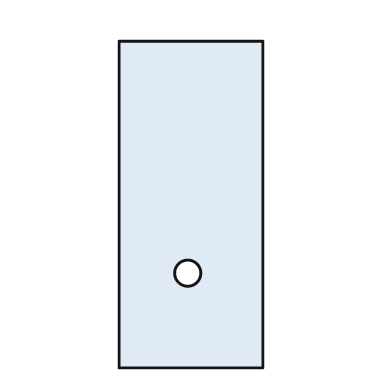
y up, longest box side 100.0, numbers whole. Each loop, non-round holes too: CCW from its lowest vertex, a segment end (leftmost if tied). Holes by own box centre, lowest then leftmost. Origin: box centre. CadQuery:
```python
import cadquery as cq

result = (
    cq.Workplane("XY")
    .moveTo(-22.0, -50.0)
    .lineTo(22.0, -50.0)
    .lineTo(22.0, 50.0)
    .lineTo(-22.0, 50.0)
    .close()
    .moveTo(-1.0, -21.0)
    .circle(4.0)
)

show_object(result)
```